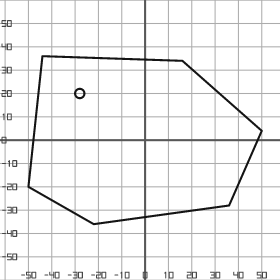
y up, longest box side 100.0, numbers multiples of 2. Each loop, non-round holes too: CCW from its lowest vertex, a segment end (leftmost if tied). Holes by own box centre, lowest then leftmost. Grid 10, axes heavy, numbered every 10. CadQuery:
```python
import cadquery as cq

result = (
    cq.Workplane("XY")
    .moveTo(-22.0, -36.0)
    .lineTo(36.0, -28.0)
    .lineTo(50.0, 4.0)
    .lineTo(16.0, 34.0)
    .lineTo(-44.0, 36.0)
    .lineTo(-50.0, -20.0)
    .close()
    .moveTo(-28.0, 20.0)
    .circle(2.0)
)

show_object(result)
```